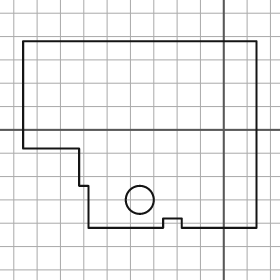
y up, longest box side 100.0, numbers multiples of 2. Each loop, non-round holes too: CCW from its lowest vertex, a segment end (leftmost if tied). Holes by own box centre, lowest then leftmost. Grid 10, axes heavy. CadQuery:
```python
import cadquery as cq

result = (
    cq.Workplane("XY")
    .moveTo(-58.0, -42.0)
    .lineTo(-26.0, -42.0)
    .lineTo(-26.0, -38.0)
    .lineTo(-18.0, -38.0)
    .lineTo(-18.0, -42.0)
    .lineTo(14.0, -42.0)
    .lineTo(14.0, 38.0)
    .lineTo(-86.0, 38.0)
    .lineTo(-86.0, -8.0)
    .lineTo(-62.0, -8.0)
    .lineTo(-62.0, -24.0)
    .lineTo(-58.0, -24.0)
    .close()
    .moveTo(-36.0, -30.0)
    .circle(6.0)
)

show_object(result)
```